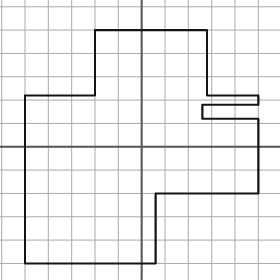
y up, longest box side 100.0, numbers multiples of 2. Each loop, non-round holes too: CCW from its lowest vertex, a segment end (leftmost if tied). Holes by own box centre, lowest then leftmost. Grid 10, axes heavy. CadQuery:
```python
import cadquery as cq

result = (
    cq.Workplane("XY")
    .moveTo(-50.0, -50.0)
    .lineTo(6.0, -50.0)
    .lineTo(6.0, -20.0)
    .lineTo(50.0, -20.0)
    .lineTo(50.0, 12.0)
    .lineTo(26.0, 12.0)
    .lineTo(26.0, 18.0)
    .lineTo(50.0, 18.0)
    .lineTo(50.0, 22.0)
    .lineTo(28.0, 22.0)
    .lineTo(28.0, 50.0)
    .lineTo(-20.0, 50.0)
    .lineTo(-20.0, 22.0)
    .lineTo(-50.0, 22.0)
    .close()
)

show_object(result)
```